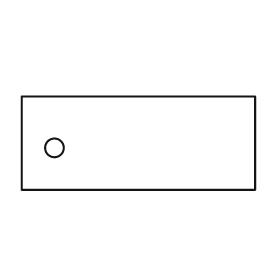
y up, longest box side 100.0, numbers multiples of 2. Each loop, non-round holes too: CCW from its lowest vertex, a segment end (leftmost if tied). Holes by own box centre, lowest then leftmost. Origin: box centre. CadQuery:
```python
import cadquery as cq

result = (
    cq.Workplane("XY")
    .moveTo(-50.0, -20.0)
    .lineTo(50.0, -20.0)
    .lineTo(50.0, 20.0)
    .lineTo(-50.0, 20.0)
    .close()
    .moveTo(-36.0, -2.0)
    .circle(4.0)
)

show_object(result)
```